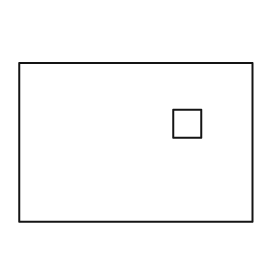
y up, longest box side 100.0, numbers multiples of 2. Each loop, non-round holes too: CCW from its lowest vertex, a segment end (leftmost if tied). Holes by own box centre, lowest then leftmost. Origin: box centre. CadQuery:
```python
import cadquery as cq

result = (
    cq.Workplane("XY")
    .moveTo(-50.0, -34.0)
    .lineTo(50.0, -34.0)
    .lineTo(50.0, 34.0)
    .lineTo(-50.0, 34.0)
    .close()
    .moveTo(16.0, 2.0)
    .lineTo(28.0, 2.0)
    .lineTo(28.0, 14.0)
    .lineTo(16.0, 14.0)
    .close()
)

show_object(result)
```